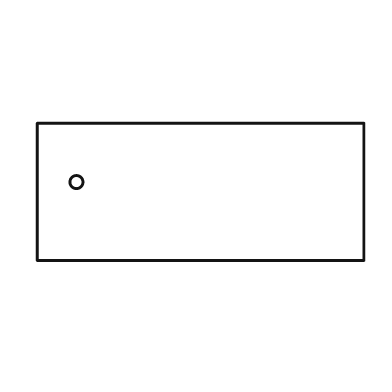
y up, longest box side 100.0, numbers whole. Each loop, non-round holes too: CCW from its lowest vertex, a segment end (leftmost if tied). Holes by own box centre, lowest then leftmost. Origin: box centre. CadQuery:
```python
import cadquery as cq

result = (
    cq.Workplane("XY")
    .moveTo(-50.0, -21.0)
    .lineTo(50.0, -21.0)
    .lineTo(50.0, 21.0)
    .lineTo(-50.0, 21.0)
    .close()
    .moveTo(-38.0, 3.0)
    .circle(2.0)
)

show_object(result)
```